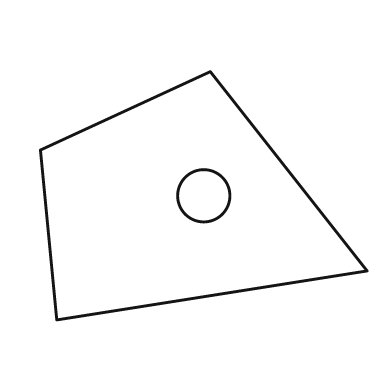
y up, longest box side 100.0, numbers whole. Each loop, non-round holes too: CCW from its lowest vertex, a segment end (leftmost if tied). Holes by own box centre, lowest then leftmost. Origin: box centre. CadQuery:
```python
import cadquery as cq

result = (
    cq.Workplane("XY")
    .moveTo(-45.0, -38.0)
    .lineTo(50.0, -23.0)
    .lineTo(2.0, 38.0)
    .lineTo(-50.0, 14.0)
    .close()
    .moveTo(0.0, 0.0)
    .circle(8.0)
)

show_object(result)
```